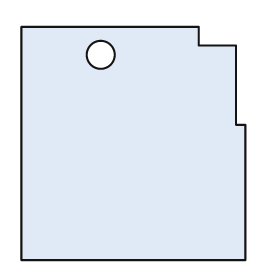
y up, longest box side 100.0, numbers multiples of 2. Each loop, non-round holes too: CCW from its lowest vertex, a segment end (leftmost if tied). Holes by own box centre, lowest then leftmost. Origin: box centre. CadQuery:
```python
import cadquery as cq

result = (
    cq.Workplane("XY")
    .moveTo(-48.0, -50.0)
    .lineTo(48.0, -50.0)
    .lineTo(48.0, 8.0)
    .lineTo(44.0, 8.0)
    .lineTo(44.0, 42.0)
    .lineTo(28.0, 42.0)
    .lineTo(28.0, 50.0)
    .lineTo(-48.0, 50.0)
    .close()
    .moveTo(-14.0, 38.0)
    .circle(6.0)
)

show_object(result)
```